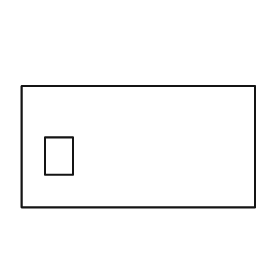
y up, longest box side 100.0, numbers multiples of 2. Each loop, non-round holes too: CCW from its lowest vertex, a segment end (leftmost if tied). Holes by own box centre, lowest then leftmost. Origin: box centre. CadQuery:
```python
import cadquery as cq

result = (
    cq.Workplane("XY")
    .moveTo(-50.0, -26.0)
    .lineTo(50.0, -26.0)
    .lineTo(50.0, 26.0)
    .lineTo(-50.0, 26.0)
    .close()
    .moveTo(-40.0, -12.0)
    .lineTo(-28.0, -12.0)
    .lineTo(-28.0, 4.0)
    .lineTo(-40.0, 4.0)
    .close()
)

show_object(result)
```